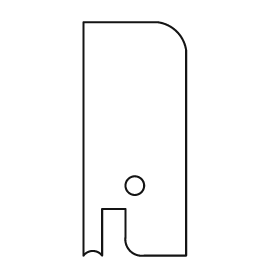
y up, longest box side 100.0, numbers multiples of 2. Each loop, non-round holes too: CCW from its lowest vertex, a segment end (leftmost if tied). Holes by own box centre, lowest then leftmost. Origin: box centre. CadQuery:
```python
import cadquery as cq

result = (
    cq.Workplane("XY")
    .moveTo(-22.0, -50.0)
    .threePointArc((-18.0, -48.0), (-14.0, -50.0))
    .lineTo(-14.0, -30.0)
    .lineTo(-4.0, -30.0)
    .lineTo(-4.0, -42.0)
    .threePointArc((-2.0, -48.0), (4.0, -50.0))
    .lineTo(22.0, -50.0)
    .lineTo(22.0, 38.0)
    .threePointArc((18.0, 46.0), (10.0, 50.0))
    .lineTo(-22.0, 50.0)
    .close()
    .moveTo(0.0, -20.0)
    .circle(4.0)
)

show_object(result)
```